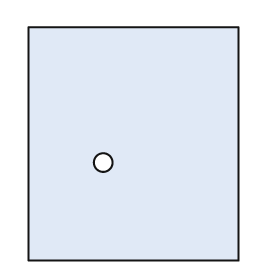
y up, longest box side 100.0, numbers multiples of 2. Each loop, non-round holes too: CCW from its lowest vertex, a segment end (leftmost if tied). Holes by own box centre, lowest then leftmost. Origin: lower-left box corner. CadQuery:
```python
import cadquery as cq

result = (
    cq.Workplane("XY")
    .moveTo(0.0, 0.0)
    .lineTo(90.0, 0.0)
    .lineTo(90.0, 100.0)
    .lineTo(0.0, 100.0)
    .close()
    .moveTo(32.0, 42.0)
    .circle(4.0)
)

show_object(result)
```